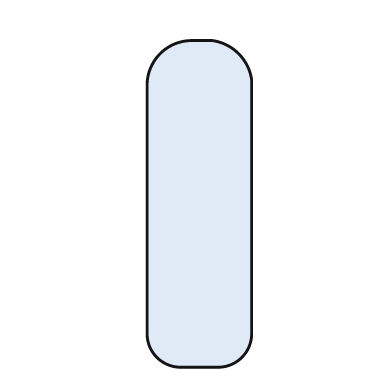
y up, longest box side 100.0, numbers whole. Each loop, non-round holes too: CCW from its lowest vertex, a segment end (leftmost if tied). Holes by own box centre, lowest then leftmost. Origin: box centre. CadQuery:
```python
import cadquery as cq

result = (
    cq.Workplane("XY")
    .moveTo(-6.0, -50.0)
    .lineTo(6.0, -50.0)
    .threePointArc((13.0, -47.0), (16.0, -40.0))
    .lineTo(16.0, 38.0)
    .threePointArc((12.0, 46.0), (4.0, 50.0))
    .lineTo(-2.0, 50.0)
    .threePointArc((-12.0, 46.0), (-16.0, 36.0))
    .lineTo(-16.0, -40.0)
    .threePointArc((-13.0, -47.0), (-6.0, -50.0))
    .close()
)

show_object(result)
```